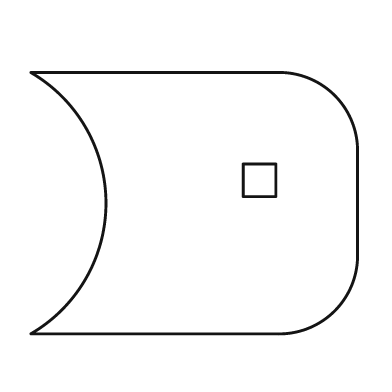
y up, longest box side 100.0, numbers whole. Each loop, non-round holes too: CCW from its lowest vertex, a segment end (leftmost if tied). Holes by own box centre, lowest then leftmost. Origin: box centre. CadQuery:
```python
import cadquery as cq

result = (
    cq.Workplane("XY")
    .moveTo(-50.0, -40.0)
    .lineTo(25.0, -40.0)
    .threePointArc((43.0, -33.0), (50.0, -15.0))
    .lineTo(50.0, 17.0)
    .threePointArc((43.0, 33.0), (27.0, 40.0))
    .lineTo(-50.0, 40.0)
    .threePointArc((-27.0, 0.0), (-50.0, -40.0))
    .close()
    .moveTo(15.0, 2.0)
    .lineTo(25.0, 2.0)
    .lineTo(25.0, 12.0)
    .lineTo(15.0, 12.0)
    .close()
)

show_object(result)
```